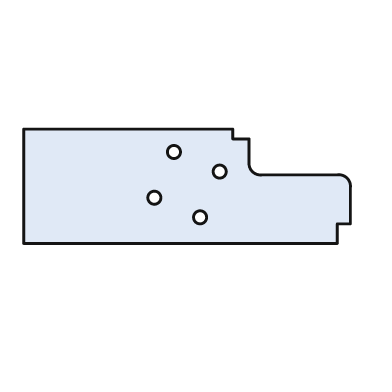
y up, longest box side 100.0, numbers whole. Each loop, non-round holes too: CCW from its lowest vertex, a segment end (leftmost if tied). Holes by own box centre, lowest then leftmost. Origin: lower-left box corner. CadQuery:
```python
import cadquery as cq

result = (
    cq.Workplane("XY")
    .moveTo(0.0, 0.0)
    .lineTo(96.0, 0.0)
    .lineTo(96.0, 6.0)
    .lineTo(100.0, 6.0)
    .lineTo(100.0, 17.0)
    .threePointArc((99.0, 20.0), (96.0, 21.0))
    .lineTo(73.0, 21.0)
    .threePointArc((70.0, 22.0), (69.0, 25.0))
    .lineTo(69.0, 32.0)
    .lineTo(64.0, 32.0)
    .lineTo(64.0, 35.0)
    .lineTo(0.0, 35.0)
    .close()
    .moveTo(54.0, 8.0)
    .circle(2.0)
    .moveTo(40.0, 14.0)
    .circle(2.0)
    .moveTo(60.0, 22.0)
    .circle(2.0)
    .moveTo(46.0, 28.0)
    .circle(2.0)
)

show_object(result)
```